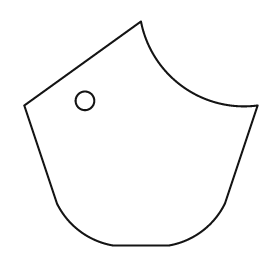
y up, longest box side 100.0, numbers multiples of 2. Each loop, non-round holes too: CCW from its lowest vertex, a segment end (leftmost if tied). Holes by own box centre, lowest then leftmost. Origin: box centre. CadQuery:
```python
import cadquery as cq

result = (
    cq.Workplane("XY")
    .moveTo(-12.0, -48.0)
    .lineTo(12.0, -48.0)
    .threePointArc((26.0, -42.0), (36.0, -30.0))
    .lineTo(50.0, 12.0)
    .threePointArc((18.0, 20.0), (0.0, 48.0))
    .lineTo(-50.0, 12.0)
    .lineTo(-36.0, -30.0)
    .threePointArc((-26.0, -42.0), (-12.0, -48.0))
    .close()
    .moveTo(-24.0, 14.0)
    .circle(4.0)
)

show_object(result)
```